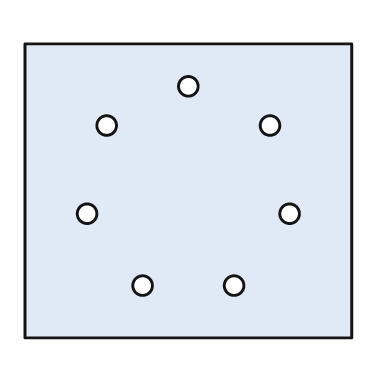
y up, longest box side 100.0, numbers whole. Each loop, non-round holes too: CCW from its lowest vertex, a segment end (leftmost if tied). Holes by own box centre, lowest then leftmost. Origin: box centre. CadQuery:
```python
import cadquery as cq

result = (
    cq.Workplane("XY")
    .moveTo(-50.0, -45.0)
    .lineTo(50.0, -45.0)
    .lineTo(50.0, 45.0)
    .lineTo(-50.0, 45.0)
    .close()
    .moveTo(-14.0, -29.0)
    .circle(3.0)
    .moveTo(14.0, -29.0)
    .circle(3.0)
    .moveTo(-31.0, -7.0)
    .circle(3.0)
    .moveTo(31.0, -7.0)
    .circle(3.0)
    .moveTo(-25.0, 20.0)
    .circle(3.0)
    .moveTo(25.0, 20.0)
    .circle(3.0)
    .moveTo(0.0, 32.0)
    .circle(3.0)
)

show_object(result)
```